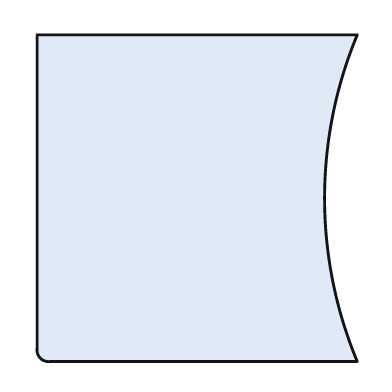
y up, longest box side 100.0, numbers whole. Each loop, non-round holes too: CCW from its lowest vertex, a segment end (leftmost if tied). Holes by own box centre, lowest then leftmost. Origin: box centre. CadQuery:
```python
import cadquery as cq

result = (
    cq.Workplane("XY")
    .moveTo(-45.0, -50.0)
    .lineTo(49.0, -50.0)
    .threePointArc((39.0, 0.0), (49.0, 50.0))
    .lineTo(-49.0, 50.0)
    .lineTo(-49.0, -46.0)
    .threePointArc((-48.0, -49.0), (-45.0, -50.0))
    .close()
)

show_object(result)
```